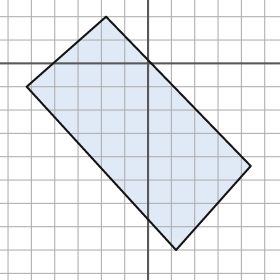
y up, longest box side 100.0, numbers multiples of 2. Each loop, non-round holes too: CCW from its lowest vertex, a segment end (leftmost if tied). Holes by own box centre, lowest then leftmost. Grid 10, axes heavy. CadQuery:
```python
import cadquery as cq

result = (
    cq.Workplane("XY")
    .moveTo(12.0, -80.0)
    .lineTo(44.0, -44.0)
    .lineTo(-18.0, 20.0)
    .lineTo(-52.0, -10.0)
    .close()
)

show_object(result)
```